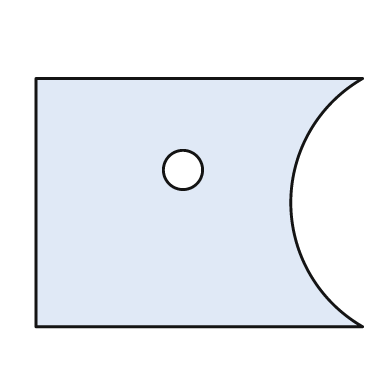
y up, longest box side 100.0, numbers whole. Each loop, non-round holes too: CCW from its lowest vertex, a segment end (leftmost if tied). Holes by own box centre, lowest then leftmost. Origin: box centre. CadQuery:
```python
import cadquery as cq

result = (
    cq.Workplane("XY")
    .moveTo(-50.0, -38.0)
    .lineTo(50.0, -38.0)
    .threePointArc((28.0, 0.0), (50.0, 38.0))
    .lineTo(-50.0, 38.0)
    .close()
    .moveTo(-5.0, 10.0)
    .circle(6.0)
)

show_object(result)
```